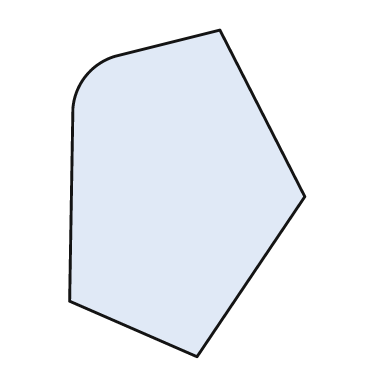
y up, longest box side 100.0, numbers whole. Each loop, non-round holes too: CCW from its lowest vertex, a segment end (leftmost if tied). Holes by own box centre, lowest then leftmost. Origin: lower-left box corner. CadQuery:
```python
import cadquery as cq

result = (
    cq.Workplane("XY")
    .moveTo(39.0, 0.0)
    .lineTo(72.0, 49.0)
    .lineTo(46.0, 100.0)
    .lineTo(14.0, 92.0)
    .threePointArc((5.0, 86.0), (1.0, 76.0))
    .lineTo(0.0, 17.0)
    .close()
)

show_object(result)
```